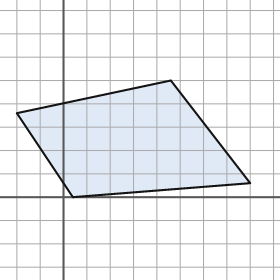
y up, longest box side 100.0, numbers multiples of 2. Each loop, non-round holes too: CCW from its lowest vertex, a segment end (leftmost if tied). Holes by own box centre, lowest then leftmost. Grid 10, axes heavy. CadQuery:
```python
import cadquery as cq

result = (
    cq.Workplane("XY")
    .moveTo(4.0, 0.0)
    .lineTo(80.0, 6.0)
    .lineTo(46.0, 50.0)
    .lineTo(-20.0, 36.0)
    .close()
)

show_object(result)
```